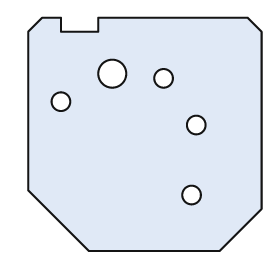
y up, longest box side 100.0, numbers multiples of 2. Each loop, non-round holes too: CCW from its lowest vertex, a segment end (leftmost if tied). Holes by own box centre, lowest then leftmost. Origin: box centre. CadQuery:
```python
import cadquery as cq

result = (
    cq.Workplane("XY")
    .moveTo(-24.0, -50.0)
    .lineTo(32.0, -50.0)
    .lineTo(50.0, -32.0)
    .lineTo(50.0, 44.0)
    .lineTo(44.0, 50.0)
    .lineTo(-20.0, 50.0)
    .lineTo(-20.0, 44.0)
    .lineTo(-36.0, 44.0)
    .lineTo(-36.0, 50.0)
    .lineTo(-44.0, 50.0)
    .lineTo(-50.0, 44.0)
    .lineTo(-50.0, -24.0)
    .close()
    .moveTo(20.0, -26.0)
    .circle(4.0)
    .moveTo(22.0, 4.0)
    .circle(4.0)
    .moveTo(-36.0, 14.0)
    .circle(4.0)
    .moveTo(8.0, 24.0)
    .circle(4.0)
    .moveTo(-14.0, 26.0)
    .circle(6.0)
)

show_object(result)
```